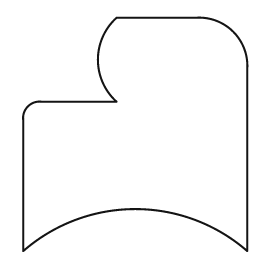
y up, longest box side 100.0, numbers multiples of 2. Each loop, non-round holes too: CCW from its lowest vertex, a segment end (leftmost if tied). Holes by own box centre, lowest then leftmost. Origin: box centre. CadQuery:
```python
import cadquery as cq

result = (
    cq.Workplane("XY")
    .moveTo(-48.0, -50.0)
    .threePointArc((0.0, -32.0), (48.0, -50.0))
    .lineTo(48.0, 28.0)
    .threePointArc((42.0, 44.0), (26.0, 50.0))
    .lineTo(-8.0, 50.0)
    .threePointArc((-16.0, 32.0), (-8.0, 14.0))
    .lineTo(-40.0, 14.0)
    .threePointArc((-46.0, 12.0), (-48.0, 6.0))
    .close()
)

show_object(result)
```